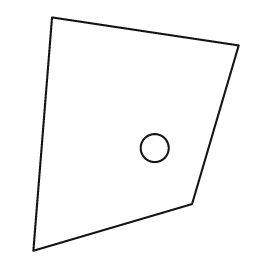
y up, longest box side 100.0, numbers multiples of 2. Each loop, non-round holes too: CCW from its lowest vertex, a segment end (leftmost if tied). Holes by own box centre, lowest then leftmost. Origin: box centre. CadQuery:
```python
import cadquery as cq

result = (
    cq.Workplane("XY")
    .moveTo(-44.0, -50.0)
    .lineTo(24.0, -30.0)
    .lineTo(44.0, 38.0)
    .lineTo(-36.0, 50.0)
    .close()
    .moveTo(8.0, -6.0)
    .circle(6.0)
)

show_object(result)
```